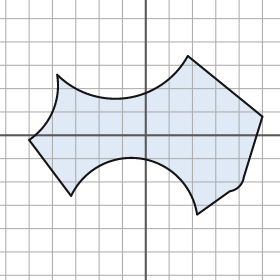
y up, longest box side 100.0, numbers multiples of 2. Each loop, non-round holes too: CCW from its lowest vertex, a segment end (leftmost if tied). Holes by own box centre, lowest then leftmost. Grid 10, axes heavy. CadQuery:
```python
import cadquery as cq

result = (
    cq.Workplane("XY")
    .moveTo(22.0, -34.0)
    .lineTo(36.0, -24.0)
    .threePointArc((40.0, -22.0), (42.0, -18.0))
    .lineTo(50.0, 8.0)
    .lineTo(18.0, 34.0)
    .threePointArc((-8.0, 16.0), (-38.0, 26.0))
    .threePointArc((-40.0, 10.0), (-50.0, -2.0))
    .lineTo(-32.0, -26.0)
    .threePointArc((-2.0, -10.0), (22.0, -34.0))
    .close()
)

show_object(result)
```